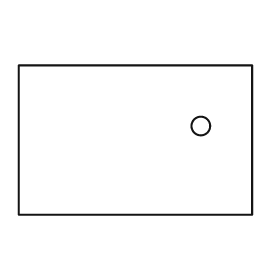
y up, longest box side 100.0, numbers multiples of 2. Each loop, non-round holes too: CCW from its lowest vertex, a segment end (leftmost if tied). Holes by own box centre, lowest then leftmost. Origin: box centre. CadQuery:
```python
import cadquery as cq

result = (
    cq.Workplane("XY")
    .moveTo(-50.0, -32.0)
    .lineTo(50.0, -32.0)
    .lineTo(50.0, 32.0)
    .lineTo(-50.0, 32.0)
    .close()
    .moveTo(28.0, 6.0)
    .circle(4.0)
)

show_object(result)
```